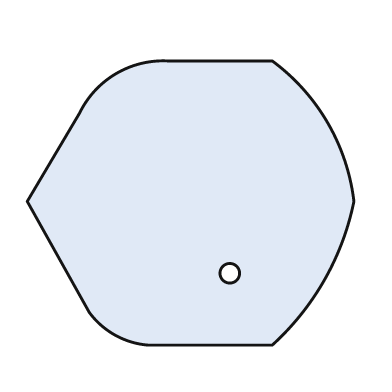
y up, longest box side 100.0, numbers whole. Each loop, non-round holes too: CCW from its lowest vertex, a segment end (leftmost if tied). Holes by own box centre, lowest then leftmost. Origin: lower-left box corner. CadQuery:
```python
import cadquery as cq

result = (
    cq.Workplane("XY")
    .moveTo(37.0, 0.0)
    .lineTo(75.0, 0.0)
    .threePointArc((91.0, 20.0), (100.0, 44.0))
    .threePointArc((92.0, 68.0), (75.0, 87.0))
    .lineTo(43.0, 87.0)
    .threePointArc((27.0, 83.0), (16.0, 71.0))
    .lineTo(0.0, 44.0)
    .lineTo(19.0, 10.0)
    .threePointArc((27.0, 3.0), (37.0, 0.0))
    .close()
    .moveTo(62.0, 22.0)
    .circle(3.0)
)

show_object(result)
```